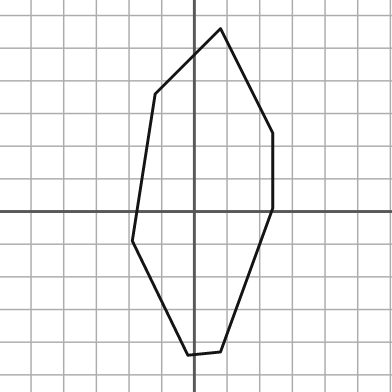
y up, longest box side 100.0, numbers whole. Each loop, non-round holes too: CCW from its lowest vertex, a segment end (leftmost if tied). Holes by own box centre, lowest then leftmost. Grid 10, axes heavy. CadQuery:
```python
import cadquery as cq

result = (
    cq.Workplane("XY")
    .moveTo(-2.0, -44.0)
    .lineTo(8.0, -43.0)
    .lineTo(24.0, 1.0)
    .lineTo(24.0, 24.0)
    .lineTo(8.0, 56.0)
    .lineTo(-12.0, 36.0)
    .lineTo(-19.0, -9.0)
    .close()
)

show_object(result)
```